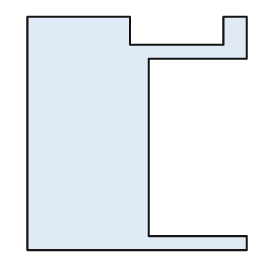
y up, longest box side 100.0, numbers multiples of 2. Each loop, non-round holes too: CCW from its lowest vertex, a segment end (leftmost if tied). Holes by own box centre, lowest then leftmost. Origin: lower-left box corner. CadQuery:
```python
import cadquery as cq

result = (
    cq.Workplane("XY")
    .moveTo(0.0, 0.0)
    .lineTo(94.0, 0.0)
    .lineTo(94.0, 6.0)
    .lineTo(52.0, 6.0)
    .lineTo(52.0, 82.0)
    .lineTo(94.0, 82.0)
    .lineTo(94.0, 100.0)
    .lineTo(84.0, 100.0)
    .lineTo(84.0, 88.0)
    .lineTo(44.0, 88.0)
    .lineTo(44.0, 100.0)
    .lineTo(0.0, 100.0)
    .close()
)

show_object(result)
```